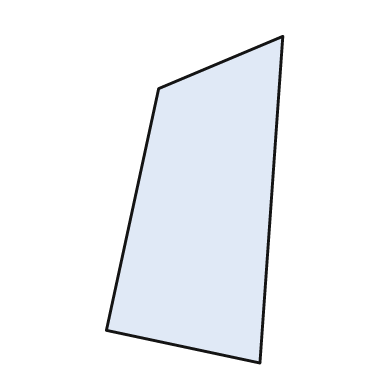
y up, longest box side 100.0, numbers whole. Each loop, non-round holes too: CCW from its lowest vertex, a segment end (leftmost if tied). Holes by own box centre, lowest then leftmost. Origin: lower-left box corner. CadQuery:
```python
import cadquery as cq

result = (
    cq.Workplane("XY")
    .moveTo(47.0, 0.0)
    .lineTo(54.0, 100.0)
    .lineTo(16.0, 84.0)
    .lineTo(0.0, 10.0)
    .close()
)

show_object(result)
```